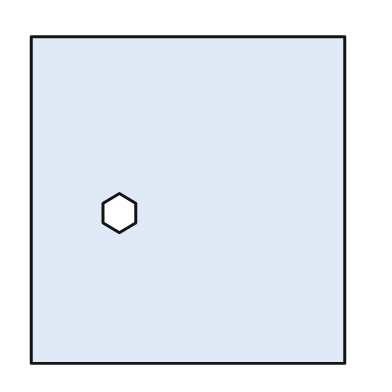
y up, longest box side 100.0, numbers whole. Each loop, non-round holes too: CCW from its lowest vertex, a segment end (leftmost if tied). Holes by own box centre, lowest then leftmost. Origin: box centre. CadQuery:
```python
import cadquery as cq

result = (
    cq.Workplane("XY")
    .moveTo(-48.0, -50.0)
    .lineTo(48.0, -50.0)
    .lineTo(48.0, 50.0)
    .lineTo(-48.0, 50.0)
    .close()
    .moveTo(-21.0, -10.0)
    .lineTo(-16.0, -7.0)
    .lineTo(-16.0, -1.0)
    .lineTo(-21.0, 2.0)
    .lineTo(-26.0, -1.0)
    .lineTo(-26.0, -7.0)
    .close()
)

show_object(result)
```